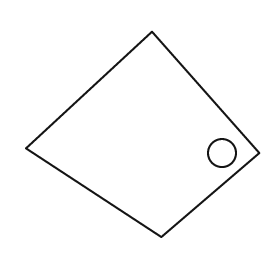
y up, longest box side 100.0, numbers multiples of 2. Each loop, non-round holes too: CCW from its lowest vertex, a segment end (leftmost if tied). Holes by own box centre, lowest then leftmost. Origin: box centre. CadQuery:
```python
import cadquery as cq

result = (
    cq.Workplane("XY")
    .moveTo(8.0, -44.0)
    .lineTo(50.0, -8.0)
    .lineTo(4.0, 44.0)
    .lineTo(-50.0, -6.0)
    .close()
    .moveTo(34.0, -8.0)
    .circle(6.0)
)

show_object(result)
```